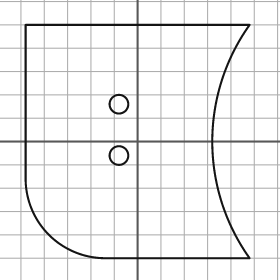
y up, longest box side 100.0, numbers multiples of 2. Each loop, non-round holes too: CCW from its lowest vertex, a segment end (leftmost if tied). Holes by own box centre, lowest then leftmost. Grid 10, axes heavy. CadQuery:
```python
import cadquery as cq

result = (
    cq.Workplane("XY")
    .moveTo(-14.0, -50.0)
    .lineTo(48.0, -50.0)
    .threePointArc((32.0, 0.0), (48.0, 50.0))
    .lineTo(-48.0, 50.0)
    .lineTo(-48.0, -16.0)
    .threePointArc((-38.0, -40.0), (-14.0, -50.0))
    .close()
    .moveTo(-8.0, -6.0)
    .circle(4.0)
    .moveTo(-8.0, 16.0)
    .circle(4.0)
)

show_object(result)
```